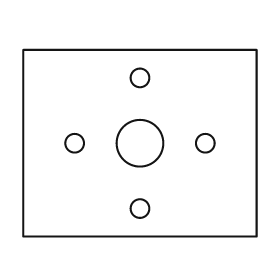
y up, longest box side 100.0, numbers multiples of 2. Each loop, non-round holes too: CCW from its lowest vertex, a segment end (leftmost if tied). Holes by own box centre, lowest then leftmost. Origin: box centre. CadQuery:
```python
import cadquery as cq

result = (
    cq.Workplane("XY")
    .moveTo(-50.0, -40.0)
    .lineTo(50.0, -40.0)
    .lineTo(50.0, 40.0)
    .lineTo(-50.0, 40.0)
    .close()
    .moveTo(0.0, -28.0)
    .circle(4.0)
    .moveTo(-28.0, 0.0)
    .circle(4.0)
    .moveTo(0.0, 0.0)
    .circle(10.0)
    .moveTo(28.0, 0.0)
    .circle(4.0)
    .moveTo(0.0, 28.0)
    .circle(4.0)
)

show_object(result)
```